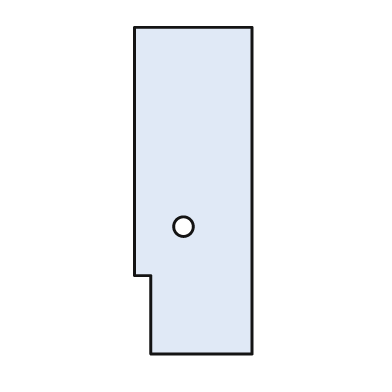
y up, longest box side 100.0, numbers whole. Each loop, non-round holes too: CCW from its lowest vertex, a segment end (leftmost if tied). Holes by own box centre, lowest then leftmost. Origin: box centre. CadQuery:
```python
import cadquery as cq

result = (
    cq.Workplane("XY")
    .moveTo(-13.0, -50.0)
    .lineTo(18.0, -50.0)
    .lineTo(18.0, 50.0)
    .lineTo(-18.0, 50.0)
    .lineTo(-18.0, -26.0)
    .lineTo(-13.0, -26.0)
    .close()
    .moveTo(-3.0, -11.0)
    .circle(3.0)
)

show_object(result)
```